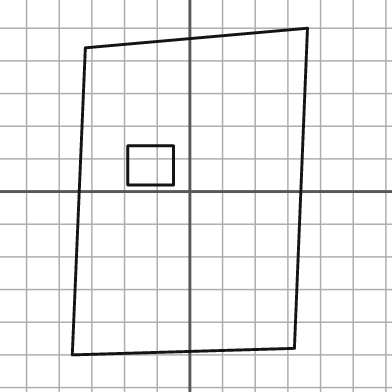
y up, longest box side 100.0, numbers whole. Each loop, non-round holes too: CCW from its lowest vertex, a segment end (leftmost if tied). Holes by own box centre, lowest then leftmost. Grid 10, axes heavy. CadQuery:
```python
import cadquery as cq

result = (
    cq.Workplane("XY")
    .moveTo(-36.0, -50.0)
    .lineTo(32.0, -48.0)
    .lineTo(36.0, 50.0)
    .lineTo(-32.0, 44.0)
    .close()
    .moveTo(-19.0, 2.0)
    .lineTo(-5.0, 2.0)
    .lineTo(-5.0, 14.0)
    .lineTo(-19.0, 14.0)
    .close()
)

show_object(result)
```